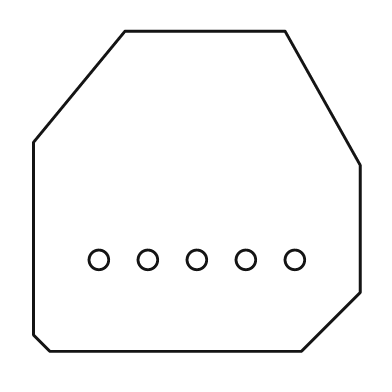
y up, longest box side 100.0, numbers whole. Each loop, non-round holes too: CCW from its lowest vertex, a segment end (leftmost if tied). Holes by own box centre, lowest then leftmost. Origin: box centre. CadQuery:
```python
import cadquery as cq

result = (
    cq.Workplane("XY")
    .moveTo(-45.0, -49.0)
    .lineTo(32.0, -49.0)
    .lineTo(50.0, -31.0)
    .lineTo(50.0, 8.0)
    .lineTo(27.0, 49.0)
    .lineTo(-22.0, 49.0)
    .lineTo(-50.0, 15.0)
    .lineTo(-50.0, -44.0)
    .close()
    .moveTo(-30.0, -21.0)
    .circle(3.0)
    .moveTo(-15.0, -21.0)
    .circle(3.0)
    .moveTo(0.0, -21.0)
    .circle(3.0)
    .moveTo(15.0, -21.0)
    .circle(3.0)
    .moveTo(30.0, -21.0)
    .circle(3.0)
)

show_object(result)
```